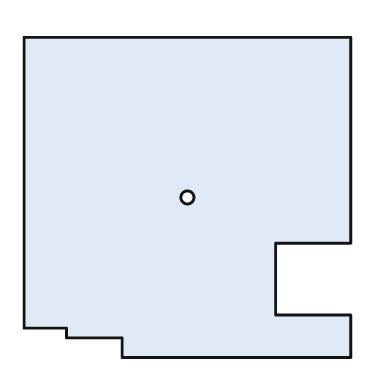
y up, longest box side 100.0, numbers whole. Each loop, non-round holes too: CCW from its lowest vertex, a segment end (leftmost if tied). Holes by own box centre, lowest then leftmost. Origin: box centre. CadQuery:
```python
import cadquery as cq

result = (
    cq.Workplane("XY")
    .moveTo(-20.0, -49.0)
    .lineTo(50.0, -49.0)
    .lineTo(50.0, -36.0)
    .lineTo(27.0, -36.0)
    .lineTo(27.0, -14.0)
    .lineTo(50.0, -14.0)
    .lineTo(50.0, 49.0)
    .lineTo(-50.0, 49.0)
    .lineTo(-50.0, -40.0)
    .lineTo(-37.0, -40.0)
    .lineTo(-37.0, -43.0)
    .lineTo(-20.0, -43.0)
    .close()
    .moveTo(0.0, 0.0)
    .circle(2.0)
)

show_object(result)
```